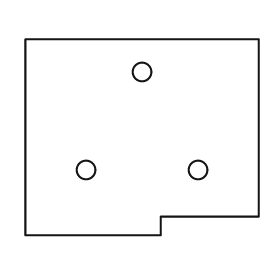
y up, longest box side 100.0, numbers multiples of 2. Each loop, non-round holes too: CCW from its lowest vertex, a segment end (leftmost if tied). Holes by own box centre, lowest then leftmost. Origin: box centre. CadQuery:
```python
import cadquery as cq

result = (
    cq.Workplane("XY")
    .moveTo(-50.0, -42.0)
    .lineTo(8.0, -42.0)
    .lineTo(8.0, -34.0)
    .lineTo(50.0, -34.0)
    .lineTo(50.0, 42.0)
    .lineTo(-50.0, 42.0)
    .close()
    .moveTo(-24.0, -14.0)
    .circle(4.0)
    .moveTo(24.0, -14.0)
    .circle(4.0)
    .moveTo(0.0, 28.0)
    .circle(4.0)
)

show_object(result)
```